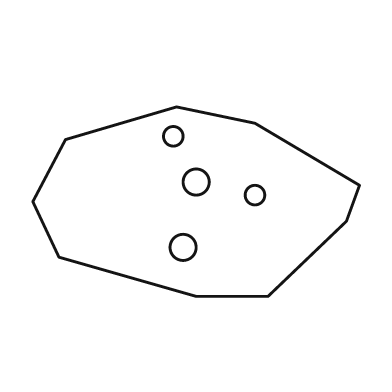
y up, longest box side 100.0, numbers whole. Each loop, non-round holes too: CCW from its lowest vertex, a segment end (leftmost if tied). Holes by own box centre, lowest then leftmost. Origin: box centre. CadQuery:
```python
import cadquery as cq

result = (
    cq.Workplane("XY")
    .moveTo(0.0, -29.0)
    .lineTo(22.0, -29.0)
    .lineTo(46.0, -6.0)
    .lineTo(50.0, 5.0)
    .lineTo(18.0, 24.0)
    .lineTo(-6.0, 29.0)
    .lineTo(-40.0, 19.0)
    .lineTo(-50.0, 0.0)
    .lineTo(-42.0, -17.0)
    .close()
    .moveTo(-4.0, -14.0)
    .circle(4.0)
    .moveTo(18.0, 2.0)
    .circle(3.0)
    .moveTo(0.0, 6.0)
    .circle(4.0)
    .moveTo(-7.0, 20.0)
    .circle(3.0)
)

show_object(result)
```